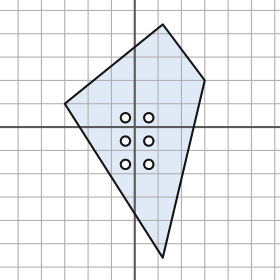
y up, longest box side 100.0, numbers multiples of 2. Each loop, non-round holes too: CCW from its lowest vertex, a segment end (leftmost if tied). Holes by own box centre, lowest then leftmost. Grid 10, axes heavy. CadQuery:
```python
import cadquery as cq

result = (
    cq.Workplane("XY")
    .moveTo(12.0, -56.0)
    .lineTo(30.0, 20.0)
    .lineTo(12.0, 44.0)
    .lineTo(-30.0, 10.0)
    .close()
    .moveTo(-4.0, -16.0)
    .circle(2.0)
    .moveTo(6.0, -16.0)
    .circle(2.0)
    .moveTo(-4.0, -6.0)
    .circle(2.0)
    .moveTo(6.0, -6.0)
    .circle(2.0)
    .moveTo(-4.0, 4.0)
    .circle(2.0)
    .moveTo(6.0, 4.0)
    .circle(2.0)
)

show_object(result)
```